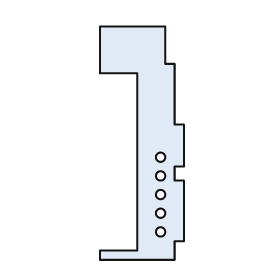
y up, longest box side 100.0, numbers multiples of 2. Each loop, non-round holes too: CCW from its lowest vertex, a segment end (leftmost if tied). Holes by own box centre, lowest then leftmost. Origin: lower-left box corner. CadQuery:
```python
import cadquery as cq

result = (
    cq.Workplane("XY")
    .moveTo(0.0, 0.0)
    .lineTo(32.0, 0.0)
    .lineTo(32.0, 8.0)
    .lineTo(36.0, 8.0)
    .lineTo(36.0, 34.0)
    .lineTo(32.0, 34.0)
    .lineTo(32.0, 40.0)
    .lineTo(36.0, 40.0)
    .lineTo(36.0, 58.0)
    .lineTo(32.0, 58.0)
    .lineTo(32.0, 84.0)
    .lineTo(28.0, 84.0)
    .lineTo(28.0, 100.0)
    .lineTo(0.0, 100.0)
    .lineTo(0.0, 80.0)
    .lineTo(16.0, 80.0)
    .lineTo(16.0, 4.0)
    .lineTo(0.0, 4.0)
    .close()
    .moveTo(26.0, 12.0)
    .circle(2.0)
    .moveTo(26.0, 20.0)
    .circle(2.0)
    .moveTo(26.0, 28.0)
    .circle(2.0)
    .moveTo(26.0, 36.0)
    .circle(2.0)
    .moveTo(26.0, 44.0)
    .circle(2.0)
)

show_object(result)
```